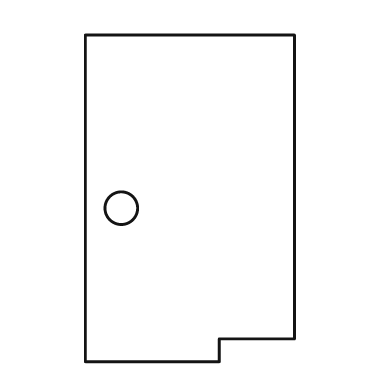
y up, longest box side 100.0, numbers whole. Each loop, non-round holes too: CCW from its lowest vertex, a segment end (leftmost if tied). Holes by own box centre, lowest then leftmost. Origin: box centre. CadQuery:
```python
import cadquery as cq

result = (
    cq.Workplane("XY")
    .moveTo(-32.0, -50.0)
    .lineTo(9.0, -50.0)
    .lineTo(9.0, -43.0)
    .lineTo(32.0, -43.0)
    .lineTo(32.0, 50.0)
    .lineTo(-32.0, 50.0)
    .close()
    .moveTo(-21.0, -3.0)
    .circle(5.0)
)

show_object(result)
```